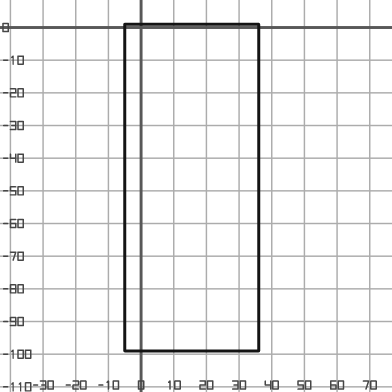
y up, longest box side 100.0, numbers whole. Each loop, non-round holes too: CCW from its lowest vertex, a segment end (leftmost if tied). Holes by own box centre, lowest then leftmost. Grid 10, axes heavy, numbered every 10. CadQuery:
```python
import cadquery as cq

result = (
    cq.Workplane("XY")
    .moveTo(-5.0, -99.0)
    .lineTo(36.0, -99.0)
    .lineTo(36.0, 1.0)
    .lineTo(-5.0, 1.0)
    .close()
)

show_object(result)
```